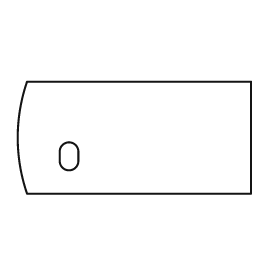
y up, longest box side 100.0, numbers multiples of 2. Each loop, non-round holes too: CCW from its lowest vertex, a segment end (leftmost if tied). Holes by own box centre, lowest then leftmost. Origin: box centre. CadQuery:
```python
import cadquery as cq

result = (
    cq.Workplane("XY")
    .moveTo(-46.0, -24.0)
    .lineTo(50.0, -24.0)
    .lineTo(50.0, 24.0)
    .lineTo(-46.0, 24.0)
    .threePointArc((-50.0, 0.0), (-46.0, -24.0))
    .close()
    .moveTo(-32.0, -10.0)
    .threePointArc((-28.0, -14.0), (-24.0, -10.0))
    .lineTo(-24.0, -6.0)
    .threePointArc((-28.0, -2.0), (-32.0, -6.0))
    .close()
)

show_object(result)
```